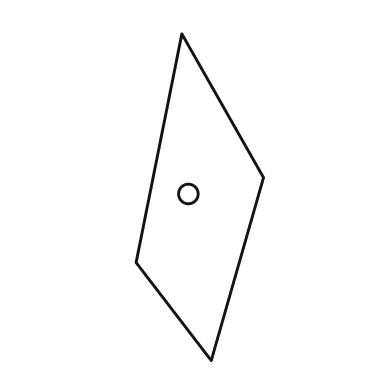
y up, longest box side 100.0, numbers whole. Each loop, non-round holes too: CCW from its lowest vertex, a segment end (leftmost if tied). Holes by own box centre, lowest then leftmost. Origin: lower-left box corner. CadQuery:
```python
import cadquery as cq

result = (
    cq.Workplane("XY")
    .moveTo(23.0, 0.0)
    .lineTo(39.0, 56.0)
    .lineTo(14.0, 100.0)
    .lineTo(0.0, 30.0)
    .close()
    .moveTo(16.0, 51.0)
    .circle(3.0)
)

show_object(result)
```